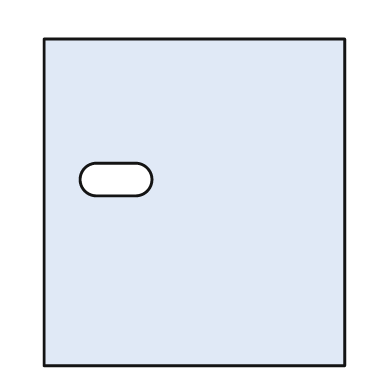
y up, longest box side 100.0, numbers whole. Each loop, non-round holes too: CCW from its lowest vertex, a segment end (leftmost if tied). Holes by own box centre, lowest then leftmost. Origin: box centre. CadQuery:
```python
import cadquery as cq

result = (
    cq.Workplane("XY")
    .moveTo(-46.0, -50.0)
    .lineTo(46.0, -50.0)
    .lineTo(46.0, 50.0)
    .lineTo(-46.0, 50.0)
    .close()
    .moveTo(-30.0, 2.0)
    .lineTo(-18.0, 2.0)
    .threePointArc((-13.0, 7.0), (-18.0, 12.0))
    .lineTo(-30.0, 12.0)
    .threePointArc((-35.0, 7.0), (-30.0, 2.0))
    .close()
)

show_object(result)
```